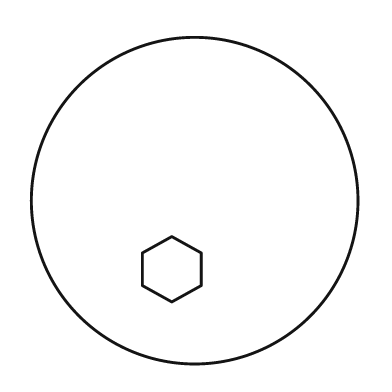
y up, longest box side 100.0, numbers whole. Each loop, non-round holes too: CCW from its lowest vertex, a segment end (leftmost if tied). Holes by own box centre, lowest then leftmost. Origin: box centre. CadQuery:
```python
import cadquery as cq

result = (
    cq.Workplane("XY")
    .moveTo(0.0, 0.0)
    .circle(50.0)
    .moveTo(-7.0, -31.0)
    .lineTo(2.0, -26.0)
    .lineTo(2.0, -16.0)
    .lineTo(-7.0, -11.0)
    .lineTo(-16.0, -16.0)
    .lineTo(-16.0, -26.0)
    .close()
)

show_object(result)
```